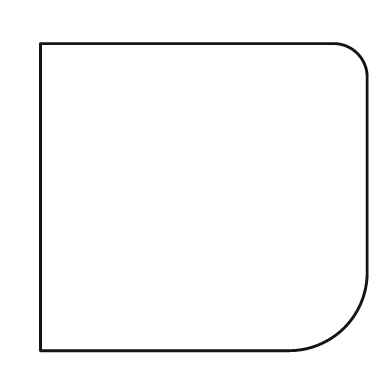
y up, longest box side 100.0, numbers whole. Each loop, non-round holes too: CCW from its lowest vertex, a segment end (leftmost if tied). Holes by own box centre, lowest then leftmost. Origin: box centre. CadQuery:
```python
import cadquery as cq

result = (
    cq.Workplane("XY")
    .moveTo(-50.0, -47.0)
    .lineTo(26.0, -47.0)
    .threePointArc((43.0, -40.0), (50.0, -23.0))
    .lineTo(50.0, 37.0)
    .threePointArc((47.0, 44.0), (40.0, 47.0))
    .lineTo(-50.0, 47.0)
    .close()
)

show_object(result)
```